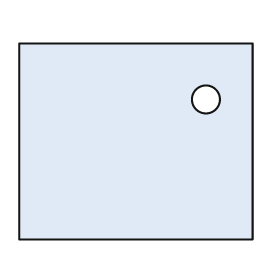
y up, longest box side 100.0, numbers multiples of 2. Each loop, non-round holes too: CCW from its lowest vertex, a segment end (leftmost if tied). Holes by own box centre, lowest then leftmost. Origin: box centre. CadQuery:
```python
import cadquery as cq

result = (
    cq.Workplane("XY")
    .moveTo(-50.0, -42.0)
    .lineTo(50.0, -42.0)
    .lineTo(50.0, 42.0)
    .lineTo(-50.0, 42.0)
    .close()
    .moveTo(30.0, 18.0)
    .circle(6.0)
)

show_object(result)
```